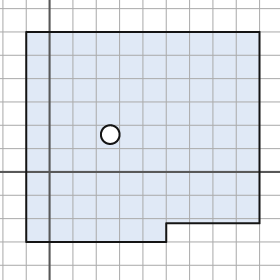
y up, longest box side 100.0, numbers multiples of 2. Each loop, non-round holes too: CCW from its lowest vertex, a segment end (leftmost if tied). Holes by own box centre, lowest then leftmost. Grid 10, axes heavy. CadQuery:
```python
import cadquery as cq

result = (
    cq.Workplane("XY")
    .moveTo(-10.0, -30.0)
    .lineTo(50.0, -30.0)
    .lineTo(50.0, -22.0)
    .lineTo(90.0, -22.0)
    .lineTo(90.0, 60.0)
    .lineTo(-10.0, 60.0)
    .close()
    .moveTo(26.0, 16.0)
    .circle(4.0)
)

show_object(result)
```